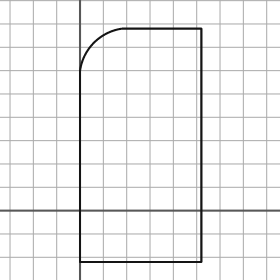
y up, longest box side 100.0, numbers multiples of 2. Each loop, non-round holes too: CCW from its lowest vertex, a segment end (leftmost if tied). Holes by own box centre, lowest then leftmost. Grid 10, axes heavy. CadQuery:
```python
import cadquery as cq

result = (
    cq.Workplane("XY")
    .moveTo(0.0, -22.0)
    .lineTo(52.0, -22.0)
    .lineTo(52.0, 78.0)
    .lineTo(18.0, 78.0)
    .threePointArc((6.0, 72.0), (0.0, 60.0))
    .close()
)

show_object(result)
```